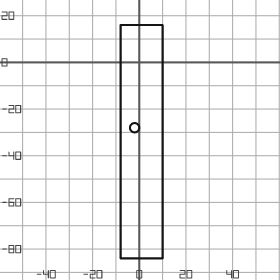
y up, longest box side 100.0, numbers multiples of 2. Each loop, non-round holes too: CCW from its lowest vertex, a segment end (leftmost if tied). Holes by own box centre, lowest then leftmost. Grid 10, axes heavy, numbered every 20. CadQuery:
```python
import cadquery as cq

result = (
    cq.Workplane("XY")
    .moveTo(-8.0, -84.0)
    .lineTo(10.0, -84.0)
    .lineTo(10.0, 16.0)
    .lineTo(-8.0, 16.0)
    .close()
    .moveTo(-2.0, -28.0)
    .circle(2.0)
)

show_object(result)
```